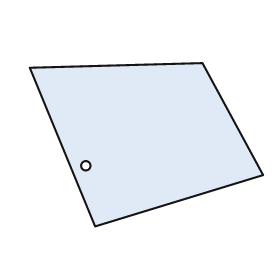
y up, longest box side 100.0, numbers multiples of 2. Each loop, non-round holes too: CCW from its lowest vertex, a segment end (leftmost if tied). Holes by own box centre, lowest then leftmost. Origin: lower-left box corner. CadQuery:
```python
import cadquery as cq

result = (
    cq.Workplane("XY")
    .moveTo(28.0, 0.0)
    .lineTo(100.0, 22.0)
    .lineTo(74.0, 70.0)
    .lineTo(0.0, 68.0)
    .close()
    .moveTo(24.0, 26.0)
    .circle(2.0)
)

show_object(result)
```